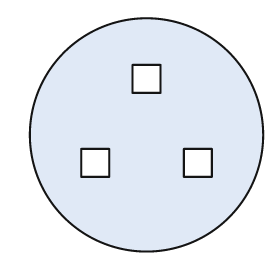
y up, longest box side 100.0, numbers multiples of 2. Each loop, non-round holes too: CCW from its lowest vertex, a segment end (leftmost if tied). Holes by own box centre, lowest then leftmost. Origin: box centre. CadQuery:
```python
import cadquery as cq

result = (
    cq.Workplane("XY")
    .moveTo(0.0, 0.0)
    .circle(50.0)
    .moveTo(-28.0, -18.0)
    .lineTo(-16.0, -18.0)
    .lineTo(-16.0, -6.0)
    .lineTo(-28.0, -6.0)
    .close()
    .moveTo(16.0, -18.0)
    .lineTo(28.0, -18.0)
    .lineTo(28.0, -6.0)
    .lineTo(16.0, -6.0)
    .close()
    .moveTo(-6.0, 18.0)
    .lineTo(6.0, 18.0)
    .lineTo(6.0, 30.0)
    .lineTo(-6.0, 30.0)
    .close()
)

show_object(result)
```